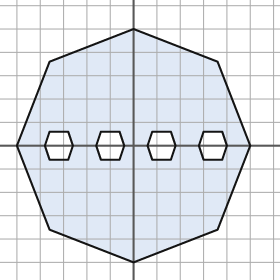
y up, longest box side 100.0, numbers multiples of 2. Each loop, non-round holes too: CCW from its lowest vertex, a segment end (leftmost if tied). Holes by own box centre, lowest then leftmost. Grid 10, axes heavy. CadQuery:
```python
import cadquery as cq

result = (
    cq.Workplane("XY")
    .moveTo(0.0, -50.0)
    .lineTo(36.0, -36.0)
    .lineTo(50.0, 0.0)
    .lineTo(36.0, 36.0)
    .lineTo(0.0, 50.0)
    .lineTo(-36.0, 36.0)
    .lineTo(-50.0, 0.0)
    .lineTo(-36.0, -36.0)
    .close()
    .moveTo(-36.0, -6.0)
    .lineTo(-28.0, -6.0)
    .lineTo(-26.0, 0.0)
    .lineTo(-28.0, 6.0)
    .lineTo(-36.0, 6.0)
    .lineTo(-38.0, 0.0)
    .close()
    .moveTo(-14.0, -6.0)
    .lineTo(-6.0, -6.0)
    .lineTo(-4.0, 0.0)
    .lineTo(-6.0, 6.0)
    .lineTo(-14.0, 6.0)
    .lineTo(-16.0, 0.0)
    .close()
    .moveTo(8.0, -6.0)
    .lineTo(16.0, -6.0)
    .lineTo(18.0, 0.0)
    .lineTo(16.0, 6.0)
    .lineTo(8.0, 6.0)
    .lineTo(6.0, 0.0)
    .close()
    .moveTo(30.0, -6.0)
    .lineTo(38.0, -6.0)
    .lineTo(40.0, 0.0)
    .lineTo(38.0, 6.0)
    .lineTo(30.0, 6.0)
    .lineTo(28.0, 0.0)
    .close()
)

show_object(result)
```